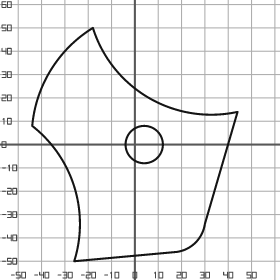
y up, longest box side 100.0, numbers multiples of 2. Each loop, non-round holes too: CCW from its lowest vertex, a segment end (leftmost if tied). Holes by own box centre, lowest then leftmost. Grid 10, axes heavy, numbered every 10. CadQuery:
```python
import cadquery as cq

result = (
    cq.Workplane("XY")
    .moveTo(-26.0, -50.0)
    .lineTo(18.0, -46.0)
    .threePointArc((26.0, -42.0), (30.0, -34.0))
    .lineTo(44.0, 14.0)
    .threePointArc((6.0, 20.0), (-18.0, 50.0))
    .threePointArc((-36.0, 32.0), (-44.0, 8.0))
    .threePointArc((-26.0, -18.0), (-26.0, -50.0))
    .close()
    .moveTo(4.0, 0.0)
    .circle(8.0)
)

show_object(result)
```